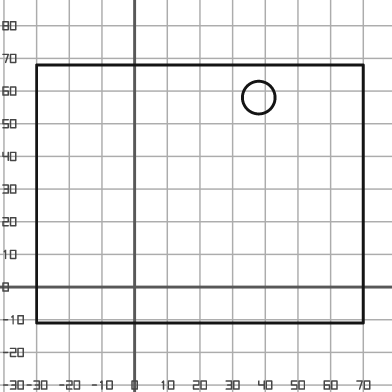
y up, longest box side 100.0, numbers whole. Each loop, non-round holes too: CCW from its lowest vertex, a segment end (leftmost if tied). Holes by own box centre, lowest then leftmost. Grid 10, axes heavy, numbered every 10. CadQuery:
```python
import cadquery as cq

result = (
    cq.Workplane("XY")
    .moveTo(-30.0, -11.0)
    .lineTo(70.0, -11.0)
    .lineTo(70.0, 68.0)
    .lineTo(-30.0, 68.0)
    .close()
    .moveTo(38.0, 58.0)
    .circle(5.0)
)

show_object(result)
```